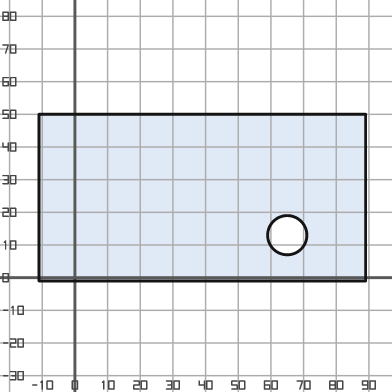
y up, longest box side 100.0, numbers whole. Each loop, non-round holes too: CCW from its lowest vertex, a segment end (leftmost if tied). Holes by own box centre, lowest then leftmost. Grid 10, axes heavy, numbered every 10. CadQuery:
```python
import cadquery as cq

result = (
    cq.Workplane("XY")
    .moveTo(-11.0, -1.0)
    .lineTo(89.0, -1.0)
    .lineTo(89.0, 50.0)
    .lineTo(-11.0, 50.0)
    .close()
    .moveTo(65.0, 13.0)
    .circle(6.0)
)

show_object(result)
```